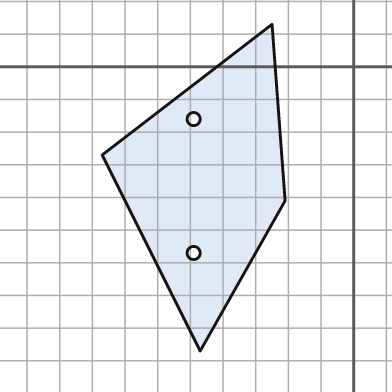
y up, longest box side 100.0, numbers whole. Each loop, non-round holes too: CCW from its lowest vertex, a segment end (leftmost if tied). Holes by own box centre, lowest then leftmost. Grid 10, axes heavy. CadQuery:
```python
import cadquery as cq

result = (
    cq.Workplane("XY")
    .moveTo(-47.0, -87.0)
    .lineTo(-21.0, -41.0)
    .lineTo(-25.0, 13.0)
    .lineTo(-77.0, -27.0)
    .close()
    .moveTo(-49.0, -57.0)
    .circle(2.0)
    .moveTo(-49.0, -16.0)
    .circle(2.0)
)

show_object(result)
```